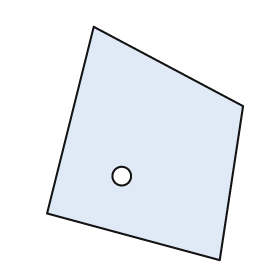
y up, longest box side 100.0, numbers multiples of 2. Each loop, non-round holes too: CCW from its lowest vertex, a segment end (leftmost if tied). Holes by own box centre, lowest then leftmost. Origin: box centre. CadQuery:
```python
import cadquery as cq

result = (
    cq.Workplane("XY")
    .moveTo(32.0, -50.0)
    .lineTo(42.0, 16.0)
    .lineTo(-22.0, 50.0)
    .lineTo(-42.0, -30.0)
    .close()
    .moveTo(-10.0, -14.0)
    .circle(4.0)
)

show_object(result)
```